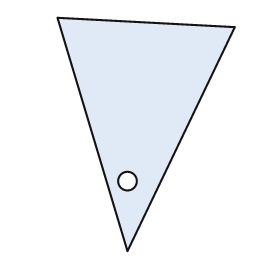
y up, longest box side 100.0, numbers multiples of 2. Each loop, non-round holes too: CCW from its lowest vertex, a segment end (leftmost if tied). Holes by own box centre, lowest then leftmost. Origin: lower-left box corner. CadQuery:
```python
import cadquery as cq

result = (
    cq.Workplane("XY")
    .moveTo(30.0, 0.0)
    .lineTo(76.0, 96.0)
    .lineTo(0.0, 100.0)
    .close()
    .moveTo(30.0, 30.0)
    .circle(4.0)
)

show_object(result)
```